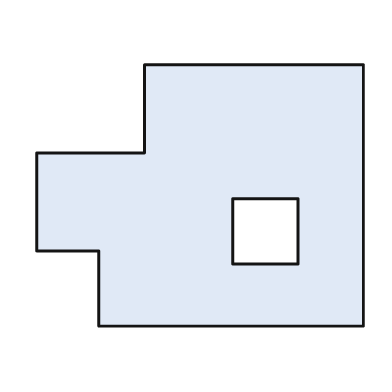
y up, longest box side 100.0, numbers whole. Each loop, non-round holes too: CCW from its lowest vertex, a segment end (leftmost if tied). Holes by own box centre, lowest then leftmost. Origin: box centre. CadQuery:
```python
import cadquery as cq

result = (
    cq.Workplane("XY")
    .moveTo(-31.0, -40.0)
    .lineTo(50.0, -40.0)
    .lineTo(50.0, 40.0)
    .lineTo(-17.0, 40.0)
    .lineTo(-17.0, 13.0)
    .lineTo(-50.0, 13.0)
    .lineTo(-50.0, -17.0)
    .lineTo(-31.0, -17.0)
    .close()
    .moveTo(10.0, -21.0)
    .lineTo(30.0, -21.0)
    .lineTo(30.0, -1.0)
    .lineTo(10.0, -1.0)
    .close()
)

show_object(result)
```